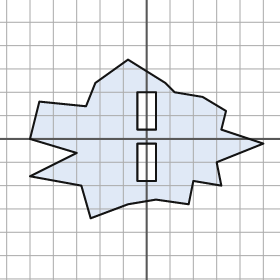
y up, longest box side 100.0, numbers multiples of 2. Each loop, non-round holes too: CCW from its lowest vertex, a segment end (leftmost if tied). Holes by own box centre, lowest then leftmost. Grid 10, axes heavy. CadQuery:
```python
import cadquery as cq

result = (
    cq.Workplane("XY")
    .moveTo(-24.0, -34.0)
    .lineTo(-8.0, -28.0)
    .lineTo(4.0, -26.0)
    .lineTo(18.0, -28.0)
    .lineTo(20.0, -18.0)
    .lineTo(32.0, -20.0)
    .lineTo(30.0, -10.0)
    .lineTo(50.0, -2.0)
    .lineTo(32.0, 4.0)
    .lineTo(34.0, 12.0)
    .lineTo(24.0, 18.0)
    .lineTo(12.0, 20.0)
    .lineTo(8.0, 24.0)
    .lineTo(-8.0, 34.0)
    .lineTo(-22.0, 24.0)
    .lineTo(-26.0, 14.0)
    .lineTo(-46.0, 16.0)
    .lineTo(-50.0, 0.0)
    .lineTo(-30.0, -6.0)
    .lineTo(-50.0, -16.0)
    .lineTo(-28.0, -20.0)
    .close()
    .moveTo(-4.0, -18.0)
    .lineTo(4.0, -18.0)
    .lineTo(4.0, -2.0)
    .lineTo(-4.0, -2.0)
    .close()
    .moveTo(-4.0, 4.0)
    .lineTo(4.0, 4.0)
    .lineTo(4.0, 20.0)
    .lineTo(-4.0, 20.0)
    .close()
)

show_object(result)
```